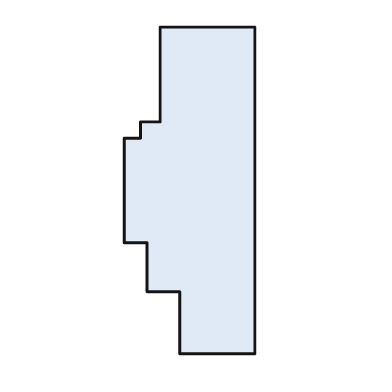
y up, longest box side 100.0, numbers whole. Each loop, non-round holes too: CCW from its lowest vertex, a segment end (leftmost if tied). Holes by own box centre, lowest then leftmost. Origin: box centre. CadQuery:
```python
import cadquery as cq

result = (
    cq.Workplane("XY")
    .moveTo(-3.0, -50.0)
    .lineTo(20.0, -50.0)
    .lineTo(20.0, 50.0)
    .lineTo(-9.0, 50.0)
    .lineTo(-9.0, 21.0)
    .lineTo(-15.0, 21.0)
    .lineTo(-15.0, 16.0)
    .lineTo(-20.0, 16.0)
    .lineTo(-20.0, -16.0)
    .lineTo(-13.0, -16.0)
    .lineTo(-13.0, -31.0)
    .lineTo(-3.0, -31.0)
    .close()
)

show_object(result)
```